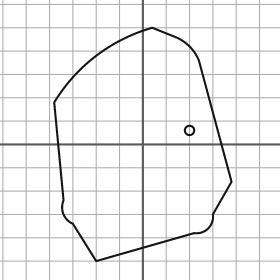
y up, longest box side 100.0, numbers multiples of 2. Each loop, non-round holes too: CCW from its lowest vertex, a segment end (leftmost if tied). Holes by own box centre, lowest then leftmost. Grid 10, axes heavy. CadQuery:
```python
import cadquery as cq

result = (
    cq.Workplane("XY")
    .moveTo(-20.0, -50.0)
    .lineTo(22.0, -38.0)
    .threePointArc((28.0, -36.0), (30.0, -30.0))
    .lineTo(38.0, -16.0)
    .lineTo(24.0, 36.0)
    .threePointArc((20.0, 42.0), (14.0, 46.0))
    .lineTo(4.0, 50.0)
    .threePointArc((-20.0, 38.0), (-38.0, 18.0))
    .lineTo(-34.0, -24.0)
    .threePointArc((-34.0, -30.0), (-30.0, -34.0))
    .close()
    .moveTo(20.0, 6.0)
    .circle(2.0)
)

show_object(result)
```